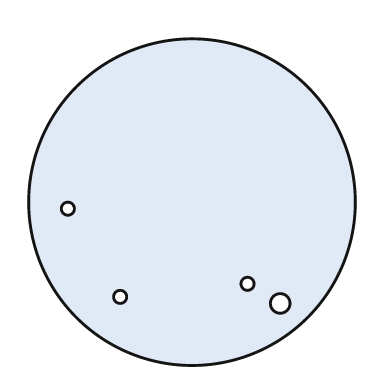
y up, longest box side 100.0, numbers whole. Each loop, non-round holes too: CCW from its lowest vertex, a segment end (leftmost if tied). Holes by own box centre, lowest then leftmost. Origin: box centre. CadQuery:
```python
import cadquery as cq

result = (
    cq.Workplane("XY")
    .moveTo(0.0, 0.0)
    .circle(50.0)
    .moveTo(27.0, -31.0)
    .circle(3.0)
    .moveTo(-22.0, -29.0)
    .circle(2.0)
    .moveTo(17.0, -25.0)
    .circle(2.0)
    .moveTo(-38.0, -2.0)
    .circle(2.0)
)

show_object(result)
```